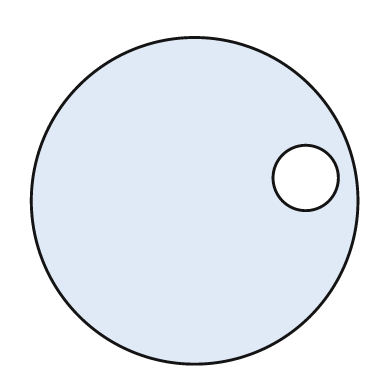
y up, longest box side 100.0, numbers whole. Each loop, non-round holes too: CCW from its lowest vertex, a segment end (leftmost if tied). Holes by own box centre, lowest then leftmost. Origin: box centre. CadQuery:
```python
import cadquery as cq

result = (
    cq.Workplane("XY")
    .moveTo(0.0, 0.0)
    .circle(50.0)
    .moveTo(34.0, 7.0)
    .circle(10.0)
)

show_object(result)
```